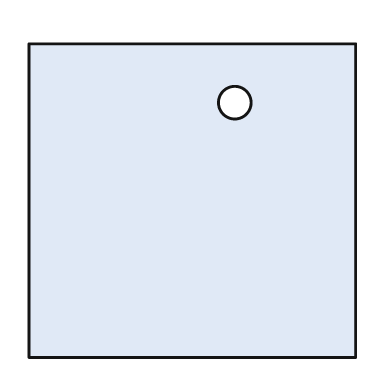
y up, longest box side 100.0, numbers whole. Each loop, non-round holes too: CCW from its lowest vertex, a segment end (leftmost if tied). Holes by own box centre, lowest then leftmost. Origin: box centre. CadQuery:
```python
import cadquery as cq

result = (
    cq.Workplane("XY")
    .moveTo(-50.0, -48.0)
    .lineTo(50.0, -48.0)
    .lineTo(50.0, 48.0)
    .lineTo(-50.0, 48.0)
    .close()
    .moveTo(13.0, 30.0)
    .circle(5.0)
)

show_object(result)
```